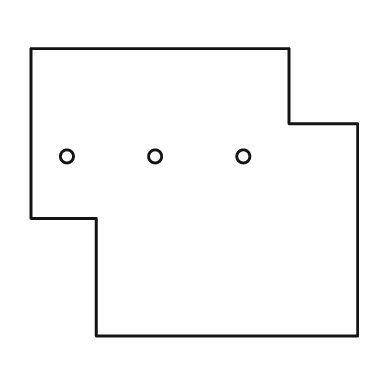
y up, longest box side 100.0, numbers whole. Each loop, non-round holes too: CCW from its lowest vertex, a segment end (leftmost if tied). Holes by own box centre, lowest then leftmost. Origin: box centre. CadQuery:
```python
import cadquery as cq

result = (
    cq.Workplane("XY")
    .moveTo(-30.0, -44.0)
    .lineTo(50.0, -44.0)
    .lineTo(50.0, 21.0)
    .lineTo(29.0, 21.0)
    .lineTo(29.0, 44.0)
    .lineTo(-50.0, 44.0)
    .lineTo(-50.0, -8.0)
    .lineTo(-30.0, -8.0)
    .close()
    .moveTo(-39.0, 11.0)
    .circle(2.0)
    .moveTo(-12.0, 11.0)
    .circle(2.0)
    .moveTo(15.0, 11.0)
    .circle(2.0)
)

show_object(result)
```